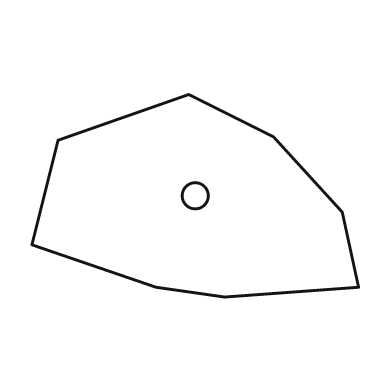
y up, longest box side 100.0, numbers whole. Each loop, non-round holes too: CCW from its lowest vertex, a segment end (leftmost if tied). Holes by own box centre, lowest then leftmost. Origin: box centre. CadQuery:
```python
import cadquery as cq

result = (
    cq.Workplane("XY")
    .moveTo(9.0, -31.0)
    .lineTo(50.0, -28.0)
    .lineTo(45.0, -5.0)
    .lineTo(24.0, 18.0)
    .lineTo(-2.0, 31.0)
    .lineTo(-42.0, 17.0)
    .lineTo(-50.0, -15.0)
    .lineTo(-12.0, -28.0)
    .close()
    .moveTo(0.0, 0.0)
    .circle(4.0)
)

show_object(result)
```